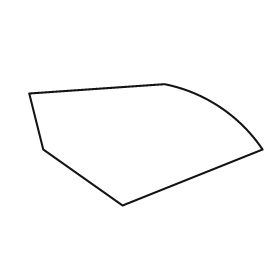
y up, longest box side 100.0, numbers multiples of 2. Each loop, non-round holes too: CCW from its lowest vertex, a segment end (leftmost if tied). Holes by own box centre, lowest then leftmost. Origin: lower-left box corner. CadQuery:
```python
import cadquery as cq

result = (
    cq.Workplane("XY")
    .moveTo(40.0, 0.0)
    .lineTo(100.0, 24.0)
    .threePointArc((82.0, 42.0), (58.0, 52.0))
    .lineTo(0.0, 48.0)
    .lineTo(6.0, 24.0)
    .close()
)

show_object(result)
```